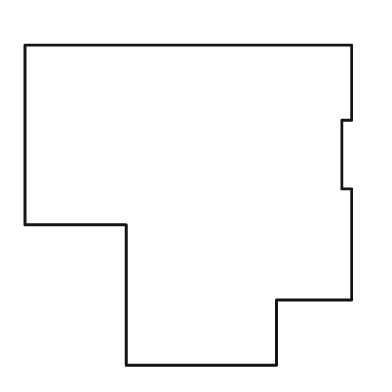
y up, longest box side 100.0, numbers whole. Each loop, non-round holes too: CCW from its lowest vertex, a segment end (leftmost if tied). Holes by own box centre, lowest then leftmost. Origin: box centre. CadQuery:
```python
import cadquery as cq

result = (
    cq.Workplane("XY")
    .moveTo(-19.0, -49.0)
    .lineTo(27.0, -49.0)
    .lineTo(27.0, -29.0)
    .lineTo(50.0, -29.0)
    .lineTo(50.0, 5.0)
    .lineTo(47.0, 5.0)
    .lineTo(47.0, 26.0)
    .lineTo(50.0, 26.0)
    .lineTo(50.0, 49.0)
    .lineTo(-50.0, 49.0)
    .lineTo(-50.0, -6.0)
    .lineTo(-19.0, -6.0)
    .close()
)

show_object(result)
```